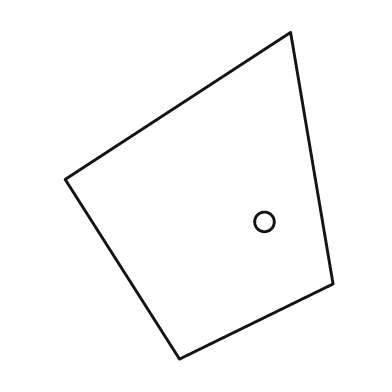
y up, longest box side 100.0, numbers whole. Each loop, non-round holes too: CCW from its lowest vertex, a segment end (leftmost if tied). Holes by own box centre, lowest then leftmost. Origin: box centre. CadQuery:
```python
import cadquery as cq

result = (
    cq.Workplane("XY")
    .moveTo(-6.0, -50.0)
    .lineTo(41.0, -27.0)
    .lineTo(28.0, 50.0)
    .lineTo(-41.0, 5.0)
    .close()
    .moveTo(20.0, -8.0)
    .circle(3.0)
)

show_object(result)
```